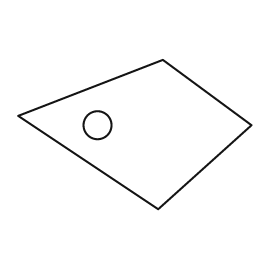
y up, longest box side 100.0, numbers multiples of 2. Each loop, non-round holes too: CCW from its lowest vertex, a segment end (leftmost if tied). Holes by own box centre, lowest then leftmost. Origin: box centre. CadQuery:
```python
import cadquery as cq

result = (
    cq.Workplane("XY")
    .moveTo(10.0, -32.0)
    .lineTo(50.0, 4.0)
    .lineTo(12.0, 32.0)
    .lineTo(-50.0, 8.0)
    .close()
    .moveTo(-16.0, 4.0)
    .circle(6.0)
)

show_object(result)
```